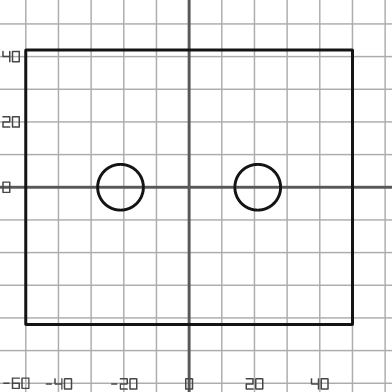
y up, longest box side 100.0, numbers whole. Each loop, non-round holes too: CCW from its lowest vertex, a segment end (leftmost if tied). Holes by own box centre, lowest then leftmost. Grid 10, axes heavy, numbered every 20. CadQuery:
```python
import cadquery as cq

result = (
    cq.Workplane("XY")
    .moveTo(-50.0, -42.0)
    .lineTo(50.0, -42.0)
    .lineTo(50.0, 42.0)
    .lineTo(-50.0, 42.0)
    .close()
    .moveTo(-21.0, 0.0)
    .circle(7.0)
    .moveTo(21.0, 0.0)
    .circle(7.0)
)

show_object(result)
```